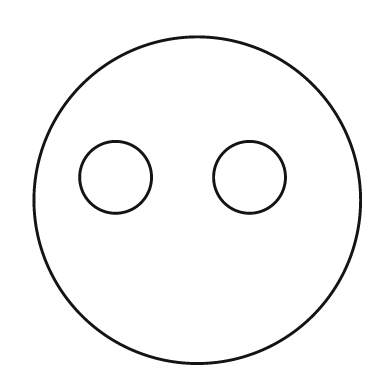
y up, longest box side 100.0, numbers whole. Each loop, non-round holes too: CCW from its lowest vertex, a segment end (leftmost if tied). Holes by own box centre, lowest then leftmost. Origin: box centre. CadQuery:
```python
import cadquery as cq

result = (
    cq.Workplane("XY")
    .moveTo(0.0, 0.0)
    .circle(50.0)
    .moveTo(-25.0, 7.0)
    .circle(11.0)
    .moveTo(16.0, 7.0)
    .circle(11.0)
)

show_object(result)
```